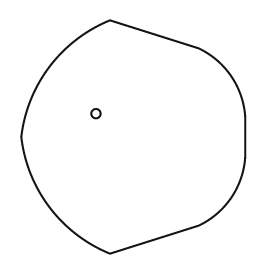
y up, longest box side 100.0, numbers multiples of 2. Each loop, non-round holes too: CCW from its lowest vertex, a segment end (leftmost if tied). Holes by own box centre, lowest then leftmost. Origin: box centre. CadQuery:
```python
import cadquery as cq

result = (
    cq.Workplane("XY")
    .moveTo(-10.0, -50.0)
    .lineTo(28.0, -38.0)
    .threePointArc((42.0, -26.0), (48.0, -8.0))
    .lineTo(48.0, 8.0)
    .threePointArc((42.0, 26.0), (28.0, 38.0))
    .lineTo(-10.0, 50.0)
    .threePointArc((-36.0, 30.0), (-48.0, 0.0))
    .threePointArc((-36.0, -30.0), (-10.0, -50.0))
    .close()
    .moveTo(-16.0, 10.0)
    .circle(2.0)
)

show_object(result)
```